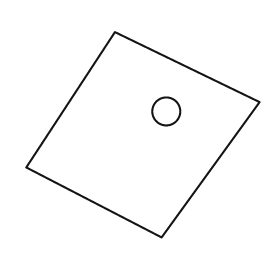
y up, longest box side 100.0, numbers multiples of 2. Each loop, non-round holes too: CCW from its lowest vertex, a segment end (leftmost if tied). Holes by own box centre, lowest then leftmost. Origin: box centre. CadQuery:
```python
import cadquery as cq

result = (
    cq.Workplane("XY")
    .moveTo(8.0, -44.0)
    .lineTo(50.0, 14.0)
    .lineTo(-12.0, 44.0)
    .lineTo(-50.0, -14.0)
    .close()
    .moveTo(10.0, 10.0)
    .circle(6.0)
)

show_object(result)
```